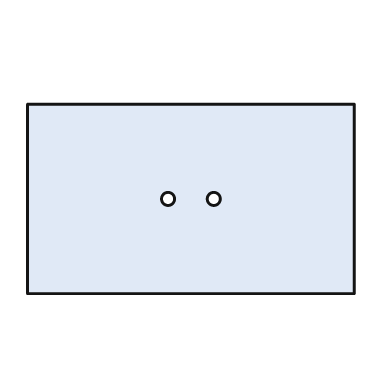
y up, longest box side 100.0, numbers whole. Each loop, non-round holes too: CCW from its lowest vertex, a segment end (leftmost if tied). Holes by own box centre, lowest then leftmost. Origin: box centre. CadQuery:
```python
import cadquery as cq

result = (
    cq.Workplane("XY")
    .moveTo(-50.0, -29.0)
    .lineTo(50.0, -29.0)
    .lineTo(50.0, 29.0)
    .lineTo(-50.0, 29.0)
    .close()
    .moveTo(-7.0, 0.0)
    .circle(2.0)
    .moveTo(7.0, 0.0)
    .circle(2.0)
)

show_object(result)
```